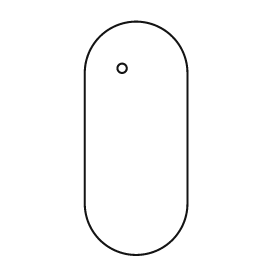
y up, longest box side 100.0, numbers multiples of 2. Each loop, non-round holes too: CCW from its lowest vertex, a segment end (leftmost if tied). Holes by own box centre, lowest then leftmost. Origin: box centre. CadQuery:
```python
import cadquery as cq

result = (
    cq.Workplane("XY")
    .moveTo(-22.0, -28.0)
    .threePointArc((0.0, -50.0), (22.0, -28.0))
    .lineTo(22.0, 28.0)
    .threePointArc((0.0, 50.0), (-22.0, 28.0))
    .close()
    .moveTo(-6.0, 30.0)
    .circle(2.0)
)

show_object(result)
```